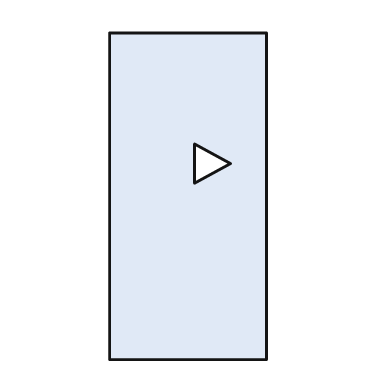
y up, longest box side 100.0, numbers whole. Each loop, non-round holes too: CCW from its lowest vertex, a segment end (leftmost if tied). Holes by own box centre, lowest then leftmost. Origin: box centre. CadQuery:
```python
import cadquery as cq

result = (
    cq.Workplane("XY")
    .moveTo(-24.0, -50.0)
    .lineTo(24.0, -50.0)
    .lineTo(24.0, 50.0)
    .lineTo(-24.0, 50.0)
    .close()
    .moveTo(2.0, 4.0)
    .lineTo(13.0, 10.0)
    .lineTo(2.0, 16.0)
    .close()
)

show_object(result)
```